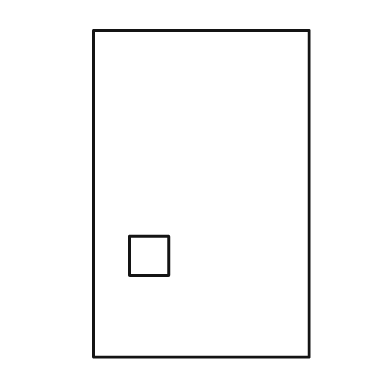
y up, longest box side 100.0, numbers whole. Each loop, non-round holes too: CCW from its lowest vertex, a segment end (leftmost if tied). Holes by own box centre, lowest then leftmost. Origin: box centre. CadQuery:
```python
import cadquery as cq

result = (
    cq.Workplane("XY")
    .moveTo(-33.0, -50.0)
    .lineTo(33.0, -50.0)
    .lineTo(33.0, 50.0)
    .lineTo(-33.0, 50.0)
    .close()
    .moveTo(-22.0, -25.0)
    .lineTo(-10.0, -25.0)
    .lineTo(-10.0, -13.0)
    .lineTo(-22.0, -13.0)
    .close()
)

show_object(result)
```